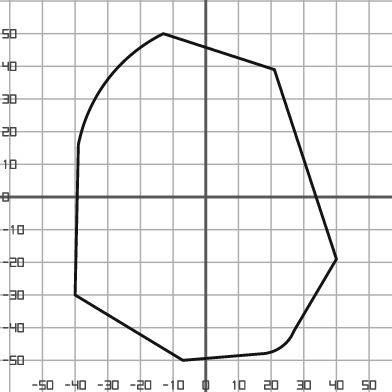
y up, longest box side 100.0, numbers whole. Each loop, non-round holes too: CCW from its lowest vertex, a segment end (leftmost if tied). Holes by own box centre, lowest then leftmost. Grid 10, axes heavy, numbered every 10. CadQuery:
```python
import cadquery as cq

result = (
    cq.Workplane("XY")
    .moveTo(-7.0, -50.0)
    .lineTo(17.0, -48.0)
    .threePointArc((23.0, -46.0), (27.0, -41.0))
    .lineTo(40.0, -19.0)
    .lineTo(21.0, 39.0)
    .lineTo(-13.0, 50.0)
    .threePointArc((-30.0, 36.0), (-39.0, 16.0))
    .lineTo(-40.0, -30.0)
    .close()
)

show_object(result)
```